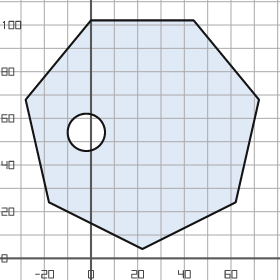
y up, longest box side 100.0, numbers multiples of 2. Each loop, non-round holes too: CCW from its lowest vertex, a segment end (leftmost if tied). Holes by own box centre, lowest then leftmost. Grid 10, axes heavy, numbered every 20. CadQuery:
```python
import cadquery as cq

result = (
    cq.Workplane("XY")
    .moveTo(22.0, 4.0)
    .lineTo(62.0, 24.0)
    .lineTo(72.0, 68.0)
    .lineTo(44.0, 102.0)
    .lineTo(0.0, 102.0)
    .lineTo(-28.0, 68.0)
    .lineTo(-18.0, 24.0)
    .close()
    .moveTo(-2.0, 54.0)
    .circle(8.0)
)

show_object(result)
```